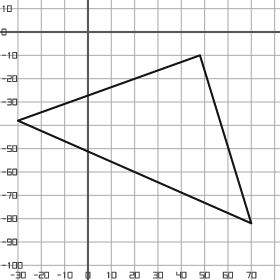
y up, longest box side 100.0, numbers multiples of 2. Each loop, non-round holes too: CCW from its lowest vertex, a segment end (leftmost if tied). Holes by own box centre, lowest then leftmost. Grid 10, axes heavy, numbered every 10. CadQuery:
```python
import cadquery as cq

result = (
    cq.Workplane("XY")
    .moveTo(70.0, -82.0)
    .lineTo(48.0, -10.0)
    .lineTo(-30.0, -38.0)
    .close()
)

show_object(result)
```